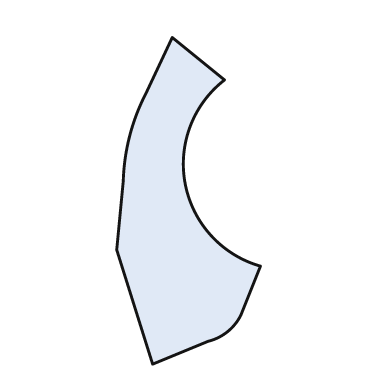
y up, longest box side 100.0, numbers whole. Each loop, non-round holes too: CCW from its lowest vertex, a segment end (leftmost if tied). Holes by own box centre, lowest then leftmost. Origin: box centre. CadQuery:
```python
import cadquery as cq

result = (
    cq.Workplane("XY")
    .moveTo(-11.0, -50.0)
    .lineTo(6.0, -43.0)
    .threePointArc((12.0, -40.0), (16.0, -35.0))
    .lineTo(22.0, -20.0)
    .threePointArc((-1.0, 5.0), (11.0, 37.0))
    .lineTo(-5.0, 50.0)
    .lineTo(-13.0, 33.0)
    .threePointArc((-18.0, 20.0), (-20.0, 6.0))
    .lineTo(-22.0, -15.0)
    .close()
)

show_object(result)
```